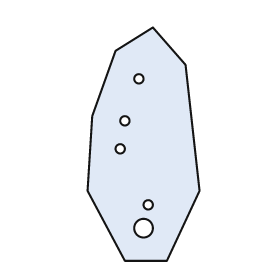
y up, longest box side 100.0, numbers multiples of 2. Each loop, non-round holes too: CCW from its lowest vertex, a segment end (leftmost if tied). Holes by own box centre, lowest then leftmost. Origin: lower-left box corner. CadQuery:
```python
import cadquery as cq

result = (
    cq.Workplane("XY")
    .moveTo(16.0, 0.0)
    .lineTo(34.0, 0.0)
    .lineTo(48.0, 30.0)
    .lineTo(42.0, 84.0)
    .lineTo(28.0, 100.0)
    .lineTo(12.0, 90.0)
    .lineTo(2.0, 62.0)
    .lineTo(0.0, 30.0)
    .close()
    .moveTo(24.0, 14.0)
    .circle(4.0)
    .moveTo(26.0, 24.0)
    .circle(2.0)
    .moveTo(14.0, 48.0)
    .circle(2.0)
    .moveTo(16.0, 60.0)
    .circle(2.0)
    .moveTo(22.0, 78.0)
    .circle(2.0)
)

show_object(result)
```